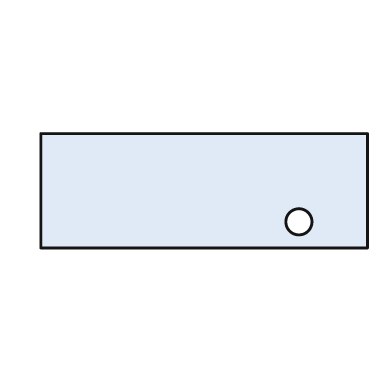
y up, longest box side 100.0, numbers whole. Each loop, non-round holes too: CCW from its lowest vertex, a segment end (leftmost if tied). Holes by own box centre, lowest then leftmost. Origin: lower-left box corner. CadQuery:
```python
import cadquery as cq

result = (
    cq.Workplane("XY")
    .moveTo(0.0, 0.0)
    .lineTo(100.0, 0.0)
    .lineTo(100.0, 35.0)
    .lineTo(0.0, 35.0)
    .close()
    .moveTo(79.0, 8.0)
    .circle(4.0)
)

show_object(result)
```